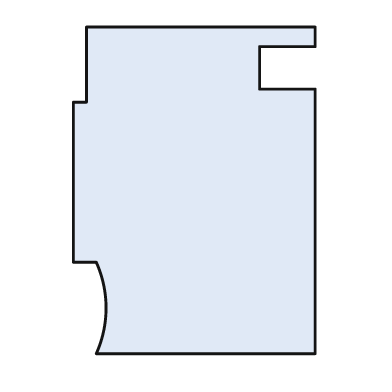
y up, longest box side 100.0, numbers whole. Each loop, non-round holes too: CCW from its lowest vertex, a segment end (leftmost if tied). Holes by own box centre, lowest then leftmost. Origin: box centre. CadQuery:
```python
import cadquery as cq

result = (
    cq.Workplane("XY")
    .moveTo(-30.0, -50.0)
    .lineTo(37.0, -50.0)
    .lineTo(37.0, 31.0)
    .lineTo(20.0, 31.0)
    .lineTo(20.0, 44.0)
    .lineTo(37.0, 44.0)
    .lineTo(37.0, 50.0)
    .lineTo(-33.0, 50.0)
    .lineTo(-33.0, 27.0)
    .lineTo(-37.0, 27.0)
    .lineTo(-37.0, -22.0)
    .lineTo(-30.0, -22.0)
    .threePointArc((-27.0, -36.0), (-30.0, -50.0))
    .close()
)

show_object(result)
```